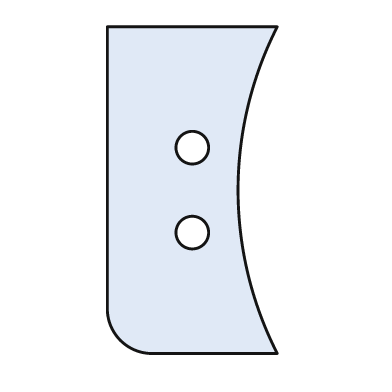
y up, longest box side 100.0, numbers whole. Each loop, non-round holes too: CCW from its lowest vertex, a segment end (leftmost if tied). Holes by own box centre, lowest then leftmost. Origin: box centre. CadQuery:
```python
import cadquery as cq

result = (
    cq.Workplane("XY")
    .moveTo(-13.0, -50.0)
    .lineTo(26.0, -50.0)
    .threePointArc((14.0, 0.0), (26.0, 50.0))
    .lineTo(-26.0, 50.0)
    .lineTo(-26.0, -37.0)
    .threePointArc((-22.0, -46.0), (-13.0, -50.0))
    .close()
    .moveTo(0.0, -13.0)
    .circle(5.0)
    .moveTo(0.0, 13.0)
    .circle(5.0)
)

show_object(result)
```